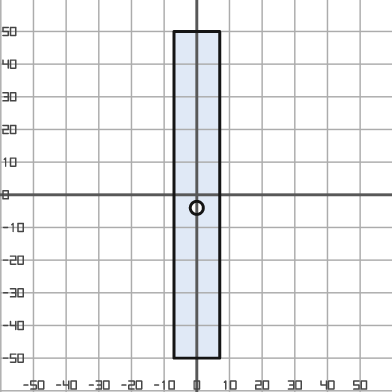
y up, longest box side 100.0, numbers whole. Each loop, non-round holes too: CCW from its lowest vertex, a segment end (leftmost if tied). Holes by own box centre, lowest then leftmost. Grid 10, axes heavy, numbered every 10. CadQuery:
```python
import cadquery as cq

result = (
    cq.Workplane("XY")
    .moveTo(-7.0, -50.0)
    .lineTo(7.0, -50.0)
    .lineTo(7.0, 50.0)
    .lineTo(-7.0, 50.0)
    .close()
    .moveTo(0.0, -4.0)
    .circle(2.0)
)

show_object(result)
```